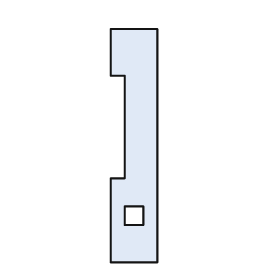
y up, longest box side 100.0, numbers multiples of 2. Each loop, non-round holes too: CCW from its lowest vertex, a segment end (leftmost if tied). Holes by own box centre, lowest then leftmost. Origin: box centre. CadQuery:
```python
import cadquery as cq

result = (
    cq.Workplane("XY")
    .moveTo(-10.0, -50.0)
    .lineTo(10.0, -50.0)
    .lineTo(10.0, 50.0)
    .lineTo(-10.0, 50.0)
    .lineTo(-10.0, 30.0)
    .lineTo(-4.0, 30.0)
    .lineTo(-4.0, -14.0)
    .lineTo(-10.0, -14.0)
    .close()
    .moveTo(-4.0, -34.0)
    .lineTo(4.0, -34.0)
    .lineTo(4.0, -26.0)
    .lineTo(-4.0, -26.0)
    .close()
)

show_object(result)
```